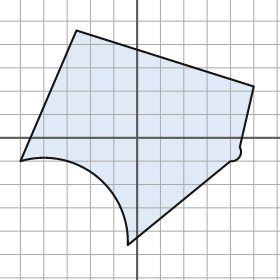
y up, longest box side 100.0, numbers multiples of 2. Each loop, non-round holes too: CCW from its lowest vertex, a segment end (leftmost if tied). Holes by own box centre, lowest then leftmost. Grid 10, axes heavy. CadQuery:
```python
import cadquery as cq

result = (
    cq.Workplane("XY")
    .moveTo(-4.0, -46.0)
    .lineTo(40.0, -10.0)
    .threePointArc((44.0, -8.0), (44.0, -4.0))
    .lineTo(50.0, 22.0)
    .lineTo(-26.0, 46.0)
    .lineTo(-50.0, -10.0)
    .threePointArc((-18.0, -16.0), (-4.0, -46.0))
    .close()
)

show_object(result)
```